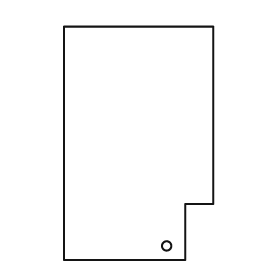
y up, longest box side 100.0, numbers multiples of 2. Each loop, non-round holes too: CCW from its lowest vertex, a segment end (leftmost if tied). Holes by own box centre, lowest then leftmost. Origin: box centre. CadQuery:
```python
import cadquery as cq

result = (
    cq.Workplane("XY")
    .moveTo(-32.0, -50.0)
    .lineTo(20.0, -50.0)
    .lineTo(20.0, -26.0)
    .lineTo(32.0, -26.0)
    .lineTo(32.0, 50.0)
    .lineTo(-32.0, 50.0)
    .close()
    .moveTo(12.0, -44.0)
    .circle(2.0)
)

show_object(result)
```